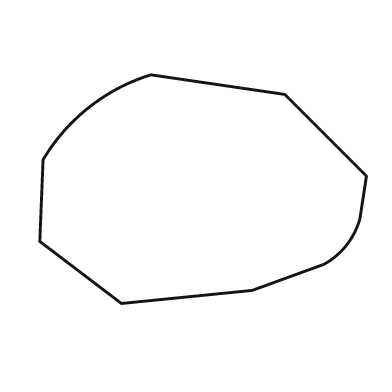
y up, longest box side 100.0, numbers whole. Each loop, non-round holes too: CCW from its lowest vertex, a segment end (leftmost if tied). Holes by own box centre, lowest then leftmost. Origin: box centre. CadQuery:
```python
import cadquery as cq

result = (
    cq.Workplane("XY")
    .moveTo(-25.0, -35.0)
    .lineTo(15.0, -31.0)
    .lineTo(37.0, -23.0)
    .threePointArc((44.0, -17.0), (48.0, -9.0))
    .lineTo(50.0, 4.0)
    .lineTo(25.0, 29.0)
    .lineTo(-16.0, 35.0)
    .threePointArc((-35.0, 25.0), (-49.0, 9.0))
    .lineTo(-50.0, -16.0)
    .close()
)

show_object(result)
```